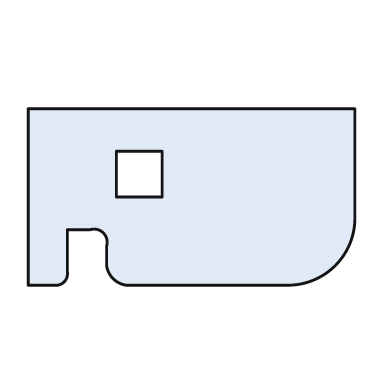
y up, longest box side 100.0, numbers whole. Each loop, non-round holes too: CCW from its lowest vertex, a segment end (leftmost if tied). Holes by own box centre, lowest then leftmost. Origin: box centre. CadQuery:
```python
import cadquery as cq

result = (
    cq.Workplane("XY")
    .moveTo(-50.0, -27.0)
    .lineTo(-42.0, -27.0)
    .threePointArc((-39.0, -26.0), (-38.0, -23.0))
    .lineTo(-38.0, -10.0)
    .lineTo(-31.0, -10.0)
    .threePointArc((-27.0, -11.0), (-26.0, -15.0))
    .lineTo(-26.0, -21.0)
    .threePointArc((-24.0, -25.0), (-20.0, -27.0))
    .lineTo(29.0, -27.0)
    .threePointArc((44.0, -21.0), (50.0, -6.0))
    .lineTo(50.0, 27.0)
    .lineTo(-50.0, 27.0)
    .close()
    .moveTo(-23.0, 0.0)
    .lineTo(-9.0, 0.0)
    .lineTo(-9.0, 14.0)
    .lineTo(-23.0, 14.0)
    .close()
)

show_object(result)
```